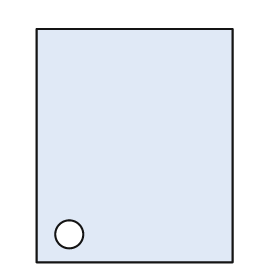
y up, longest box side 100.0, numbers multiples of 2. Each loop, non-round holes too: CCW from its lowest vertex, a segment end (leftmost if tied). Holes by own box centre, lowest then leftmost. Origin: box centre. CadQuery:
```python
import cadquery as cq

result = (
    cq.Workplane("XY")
    .moveTo(-42.0, -50.0)
    .lineTo(42.0, -50.0)
    .lineTo(42.0, 50.0)
    .lineTo(-42.0, 50.0)
    .close()
    .moveTo(-28.0, -38.0)
    .circle(6.0)
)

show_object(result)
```